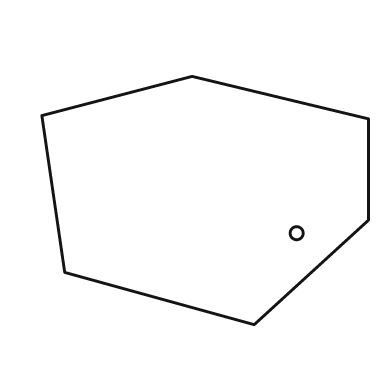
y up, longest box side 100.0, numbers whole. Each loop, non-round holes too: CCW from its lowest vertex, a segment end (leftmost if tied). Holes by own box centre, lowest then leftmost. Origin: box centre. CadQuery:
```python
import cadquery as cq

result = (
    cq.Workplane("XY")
    .moveTo(15.0, -38.0)
    .lineTo(50.0, -6.0)
    .lineTo(50.0, 25.0)
    .lineTo(-4.0, 38.0)
    .lineTo(-50.0, 26.0)
    .lineTo(-43.0, -22.0)
    .close()
    .moveTo(28.0, -10.0)
    .circle(2.0)
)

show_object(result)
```